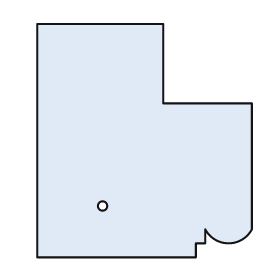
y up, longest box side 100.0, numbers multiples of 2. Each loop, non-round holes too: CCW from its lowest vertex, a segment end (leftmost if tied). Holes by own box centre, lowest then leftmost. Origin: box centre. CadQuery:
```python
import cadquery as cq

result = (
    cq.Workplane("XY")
    .moveTo(-46.0, -50.0)
    .lineTo(22.0, -50.0)
    .lineTo(22.0, -44.0)
    .lineTo(26.0, -44.0)
    .lineTo(26.0, -38.0)
    .threePointArc((36.0, -44.0), (46.0, -38.0))
    .lineTo(46.0, 16.0)
    .lineTo(8.0, 16.0)
    .lineTo(8.0, 50.0)
    .lineTo(-46.0, 50.0)
    .close()
    .moveTo(-18.0, -28.0)
    .circle(2.0)
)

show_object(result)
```